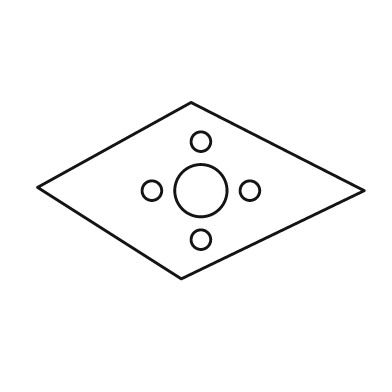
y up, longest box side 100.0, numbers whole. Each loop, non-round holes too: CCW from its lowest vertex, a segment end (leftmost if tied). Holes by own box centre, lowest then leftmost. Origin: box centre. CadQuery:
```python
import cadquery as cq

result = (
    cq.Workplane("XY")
    .moveTo(-6.0, -27.0)
    .lineTo(50.0, 0.0)
    .lineTo(-3.0, 27.0)
    .lineTo(-50.0, 1.0)
    .close()
    .moveTo(0.0, -15.0)
    .circle(3.0)
    .moveTo(-15.0, 0.0)
    .circle(3.0)
    .moveTo(0.0, 0.0)
    .circle(8.0)
    .moveTo(15.0, 0.0)
    .circle(3.0)
    .moveTo(0.0, 15.0)
    .circle(3.0)
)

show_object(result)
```